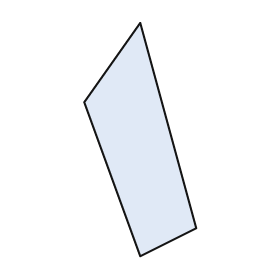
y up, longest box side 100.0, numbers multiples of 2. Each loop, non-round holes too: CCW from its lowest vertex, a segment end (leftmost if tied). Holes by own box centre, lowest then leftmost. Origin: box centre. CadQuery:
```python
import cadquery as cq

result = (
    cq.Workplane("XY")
    .moveTo(0.0, -50.0)
    .lineTo(24.0, -38.0)
    .lineTo(0.0, 50.0)
    .lineTo(-24.0, 16.0)
    .close()
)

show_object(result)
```